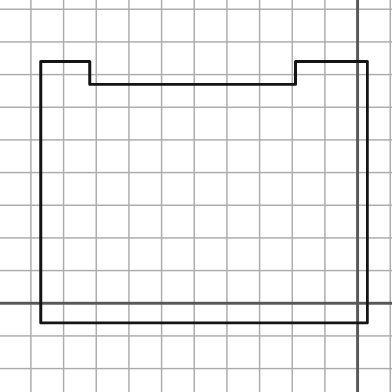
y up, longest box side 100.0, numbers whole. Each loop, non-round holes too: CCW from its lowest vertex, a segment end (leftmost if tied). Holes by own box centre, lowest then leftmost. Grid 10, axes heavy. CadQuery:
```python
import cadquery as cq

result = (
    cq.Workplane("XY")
    .moveTo(-97.0, -6.0)
    .lineTo(3.0, -6.0)
    .lineTo(3.0, 74.0)
    .lineTo(-19.0, 74.0)
    .lineTo(-19.0, 67.0)
    .lineTo(-82.0, 67.0)
    .lineTo(-82.0, 74.0)
    .lineTo(-97.0, 74.0)
    .close()
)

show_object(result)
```